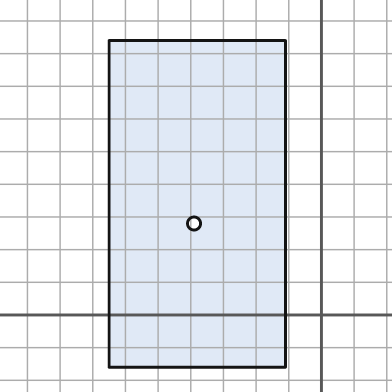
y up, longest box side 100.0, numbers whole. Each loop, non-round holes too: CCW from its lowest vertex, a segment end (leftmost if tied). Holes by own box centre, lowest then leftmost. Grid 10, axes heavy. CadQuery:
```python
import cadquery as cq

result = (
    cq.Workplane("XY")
    .moveTo(-65.0, -16.0)
    .lineTo(-11.0, -16.0)
    .lineTo(-11.0, 84.0)
    .lineTo(-65.0, 84.0)
    .close()
    .moveTo(-39.0, 28.0)
    .circle(2.0)
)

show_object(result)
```